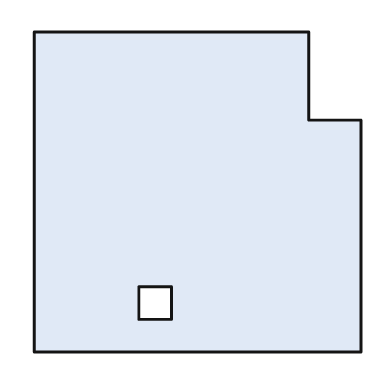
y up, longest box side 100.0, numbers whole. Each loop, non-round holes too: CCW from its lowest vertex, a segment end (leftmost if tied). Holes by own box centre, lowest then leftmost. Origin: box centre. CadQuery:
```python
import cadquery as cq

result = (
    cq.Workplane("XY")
    .moveTo(-50.0, -49.0)
    .lineTo(50.0, -49.0)
    .lineTo(50.0, 22.0)
    .lineTo(34.0, 22.0)
    .lineTo(34.0, 49.0)
    .lineTo(-50.0, 49.0)
    .close()
    .moveTo(-18.0, -39.0)
    .lineTo(-8.0, -39.0)
    .lineTo(-8.0, -29.0)
    .lineTo(-18.0, -29.0)
    .close()
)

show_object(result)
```